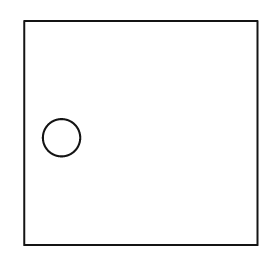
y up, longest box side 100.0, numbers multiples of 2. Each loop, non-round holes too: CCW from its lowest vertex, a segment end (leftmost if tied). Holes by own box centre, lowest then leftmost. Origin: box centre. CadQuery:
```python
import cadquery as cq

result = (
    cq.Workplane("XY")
    .moveTo(-50.0, -48.0)
    .lineTo(50.0, -48.0)
    .lineTo(50.0, 48.0)
    .lineTo(-50.0, 48.0)
    .close()
    .moveTo(-34.0, -2.0)
    .circle(8.0)
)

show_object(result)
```